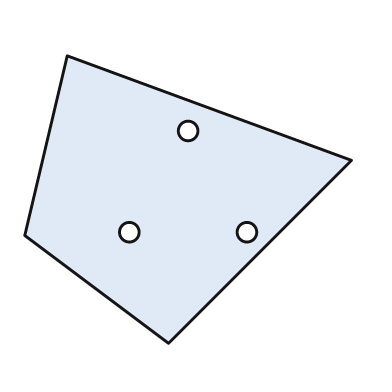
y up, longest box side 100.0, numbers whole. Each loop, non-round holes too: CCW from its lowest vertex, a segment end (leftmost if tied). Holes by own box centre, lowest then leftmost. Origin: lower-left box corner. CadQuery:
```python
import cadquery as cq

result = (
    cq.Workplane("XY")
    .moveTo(44.0, 0.0)
    .lineTo(100.0, 56.0)
    .lineTo(13.0, 88.0)
    .lineTo(0.0, 33.0)
    .close()
    .moveTo(32.0, 34.0)
    .circle(3.0)
    .moveTo(68.0, 34.0)
    .circle(3.0)
    .moveTo(50.0, 65.0)
    .circle(3.0)
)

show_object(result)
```